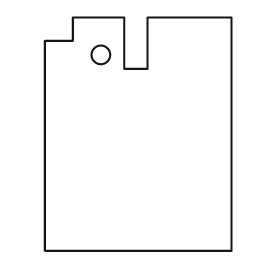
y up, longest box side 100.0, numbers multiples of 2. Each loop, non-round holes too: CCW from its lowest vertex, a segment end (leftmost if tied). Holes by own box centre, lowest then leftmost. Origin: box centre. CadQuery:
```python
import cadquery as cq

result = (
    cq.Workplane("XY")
    .moveTo(-40.0, -50.0)
    .lineTo(40.0, -50.0)
    .lineTo(40.0, 50.0)
    .lineTo(4.0, 50.0)
    .lineTo(4.0, 28.0)
    .lineTo(-6.0, 28.0)
    .lineTo(-6.0, 50.0)
    .lineTo(-28.0, 50.0)
    .lineTo(-28.0, 40.0)
    .lineTo(-40.0, 40.0)
    .close()
    .moveTo(-16.0, 34.0)
    .circle(4.0)
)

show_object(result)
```